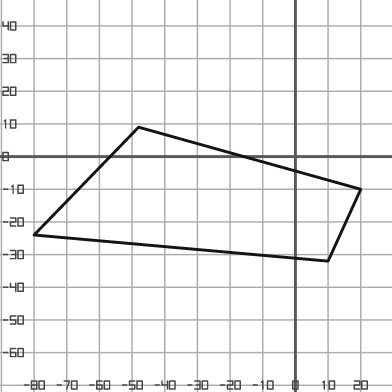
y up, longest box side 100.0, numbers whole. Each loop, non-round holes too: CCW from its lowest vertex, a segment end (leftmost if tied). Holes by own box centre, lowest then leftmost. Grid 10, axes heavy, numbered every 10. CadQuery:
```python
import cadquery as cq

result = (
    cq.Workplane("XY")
    .moveTo(10.0, -32.0)
    .lineTo(20.0, -10.0)
    .lineTo(-48.0, 9.0)
    .lineTo(-80.0, -24.0)
    .close()
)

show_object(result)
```